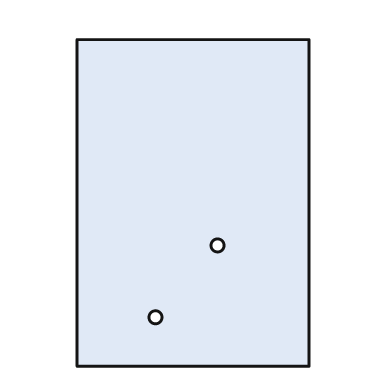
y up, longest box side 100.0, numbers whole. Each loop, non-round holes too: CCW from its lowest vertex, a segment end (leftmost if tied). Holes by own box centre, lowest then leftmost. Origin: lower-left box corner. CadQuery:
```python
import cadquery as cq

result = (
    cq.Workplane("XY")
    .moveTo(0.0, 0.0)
    .lineTo(71.0, 0.0)
    .lineTo(71.0, 100.0)
    .lineTo(0.0, 100.0)
    .close()
    .moveTo(24.0, 15.0)
    .circle(2.0)
    .moveTo(43.0, 37.0)
    .circle(2.0)
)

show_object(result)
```